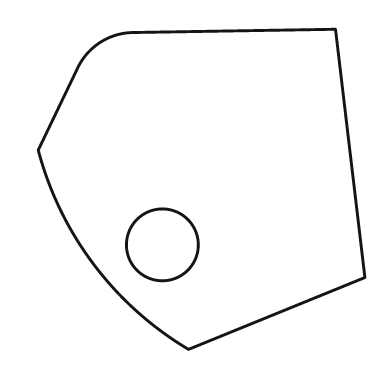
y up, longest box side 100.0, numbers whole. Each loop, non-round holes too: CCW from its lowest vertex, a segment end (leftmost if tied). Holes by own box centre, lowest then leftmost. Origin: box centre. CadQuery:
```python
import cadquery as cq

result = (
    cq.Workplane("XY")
    .moveTo(-4.0, -49.0)
    .lineTo(50.0, -27.0)
    .lineTo(41.0, 49.0)
    .lineTo(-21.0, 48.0)
    .threePointArc((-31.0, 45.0), (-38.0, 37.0))
    .lineTo(-50.0, 12.0)
    .threePointArc((-33.0, -23.0), (-4.0, -49.0))
    .close()
    .moveTo(-12.0, -17.0)
    .circle(11.0)
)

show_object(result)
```